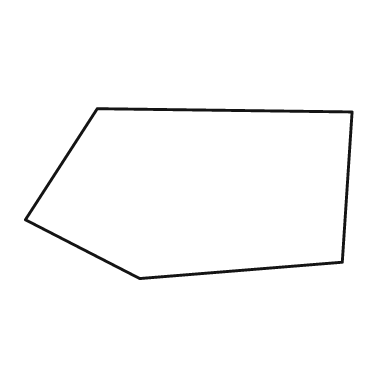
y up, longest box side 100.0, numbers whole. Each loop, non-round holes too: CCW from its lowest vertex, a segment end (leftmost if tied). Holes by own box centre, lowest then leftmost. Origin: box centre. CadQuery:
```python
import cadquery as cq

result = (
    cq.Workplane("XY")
    .moveTo(-15.0, -26.0)
    .lineTo(47.0, -21.0)
    .lineTo(50.0, 25.0)
    .lineTo(-28.0, 26.0)
    .lineTo(-50.0, -8.0)
    .close()
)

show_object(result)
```